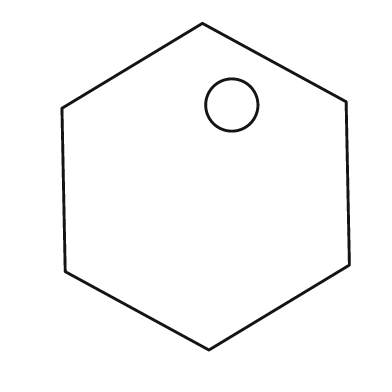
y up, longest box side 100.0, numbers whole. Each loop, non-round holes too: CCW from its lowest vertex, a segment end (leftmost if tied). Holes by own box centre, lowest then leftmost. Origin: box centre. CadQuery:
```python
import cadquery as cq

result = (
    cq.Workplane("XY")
    .moveTo(1.0, -50.0)
    .lineTo(44.0, -24.0)
    .lineTo(43.0, 26.0)
    .lineTo(-1.0, 50.0)
    .lineTo(-44.0, 24.0)
    .lineTo(-43.0, -26.0)
    .close()
    .moveTo(8.0, 25.0)
    .circle(8.0)
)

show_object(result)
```